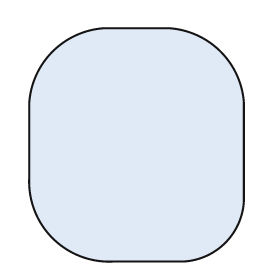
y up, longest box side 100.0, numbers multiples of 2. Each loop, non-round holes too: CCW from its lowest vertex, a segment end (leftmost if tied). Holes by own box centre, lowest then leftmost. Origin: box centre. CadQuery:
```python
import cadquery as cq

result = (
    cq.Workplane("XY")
    .moveTo(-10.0, -50.0)
    .lineTo(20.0, -50.0)
    .threePointArc((38.0, -42.0), (46.0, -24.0))
    .lineTo(46.0, 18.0)
    .threePointArc((36.0, 40.0), (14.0, 50.0))
    .lineTo(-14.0, 50.0)
    .threePointArc((-36.0, 40.0), (-46.0, 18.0))
    .lineTo(-46.0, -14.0)
    .threePointArc((-36.0, -40.0), (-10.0, -50.0))
    .close()
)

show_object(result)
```